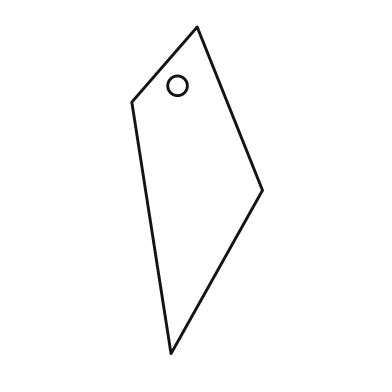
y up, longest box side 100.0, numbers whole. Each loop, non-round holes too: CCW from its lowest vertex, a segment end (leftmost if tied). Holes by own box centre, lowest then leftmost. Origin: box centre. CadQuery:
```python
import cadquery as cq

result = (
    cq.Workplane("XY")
    .moveTo(-8.0, -50.0)
    .lineTo(20.0, 0.0)
    .lineTo(0.0, 50.0)
    .lineTo(-20.0, 27.0)
    .close()
    .moveTo(-6.0, 32.0)
    .circle(3.0)
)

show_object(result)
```